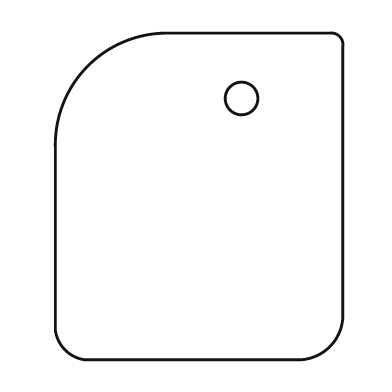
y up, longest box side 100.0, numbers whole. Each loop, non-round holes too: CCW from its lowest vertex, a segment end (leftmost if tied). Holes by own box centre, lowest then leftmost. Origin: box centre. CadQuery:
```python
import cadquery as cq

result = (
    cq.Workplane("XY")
    .moveTo(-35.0, -50.0)
    .lineTo(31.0, -50.0)
    .threePointArc((40.0, -46.0), (44.0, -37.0))
    .lineTo(44.0, 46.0)
    .threePointArc((43.0, 49.0), (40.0, 50.0))
    .lineTo(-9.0, 50.0)
    .threePointArc((-34.0, 40.0), (-44.0, 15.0))
    .lineTo(-44.0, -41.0)
    .threePointArc((-41.0, -47.0), (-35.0, -50.0))
    .close()
    .moveTo(13.0, 30.0)
    .circle(5.0)
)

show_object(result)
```